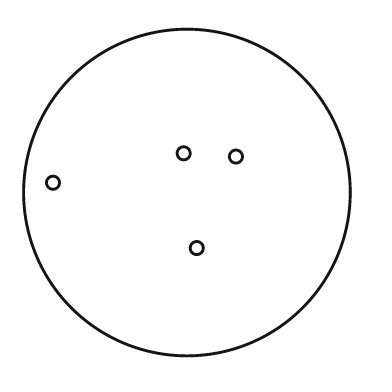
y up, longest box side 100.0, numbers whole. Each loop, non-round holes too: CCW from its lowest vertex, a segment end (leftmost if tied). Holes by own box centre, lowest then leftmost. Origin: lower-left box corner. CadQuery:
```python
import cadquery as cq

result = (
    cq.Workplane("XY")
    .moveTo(50.0, 50.0)
    .circle(50.0)
    .moveTo(53.0, 33.0)
    .circle(2.0)
    .moveTo(9.0, 53.0)
    .circle(2.0)
    .moveTo(65.0, 61.0)
    .circle(2.0)
    .moveTo(49.0, 62.0)
    .circle(2.0)
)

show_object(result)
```